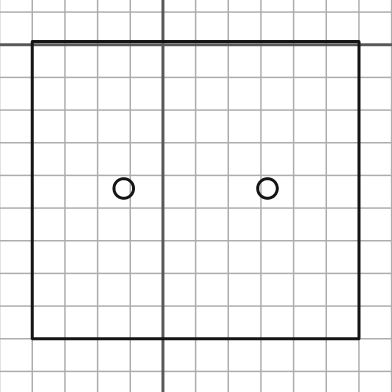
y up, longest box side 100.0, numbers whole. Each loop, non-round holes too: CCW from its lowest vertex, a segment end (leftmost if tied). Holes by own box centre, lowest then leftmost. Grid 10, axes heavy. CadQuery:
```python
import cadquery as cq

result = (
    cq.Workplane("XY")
    .moveTo(-40.0, -90.0)
    .lineTo(60.0, -90.0)
    .lineTo(60.0, 1.0)
    .lineTo(-40.0, 1.0)
    .close()
    .moveTo(-12.0, -44.0)
    .circle(3.0)
    .moveTo(32.0, -44.0)
    .circle(3.0)
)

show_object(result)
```